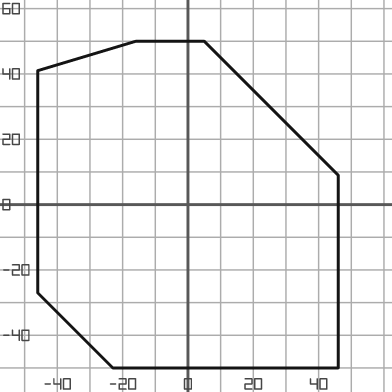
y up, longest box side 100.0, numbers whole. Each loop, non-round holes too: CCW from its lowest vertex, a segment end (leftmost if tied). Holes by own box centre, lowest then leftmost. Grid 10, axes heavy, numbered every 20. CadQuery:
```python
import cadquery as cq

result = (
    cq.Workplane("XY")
    .moveTo(-23.0, -50.0)
    .lineTo(46.0, -50.0)
    .lineTo(46.0, 9.0)
    .lineTo(5.0, 50.0)
    .lineTo(-16.0, 50.0)
    .lineTo(-46.0, 41.0)
    .lineTo(-46.0, -27.0)
    .close()
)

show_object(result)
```